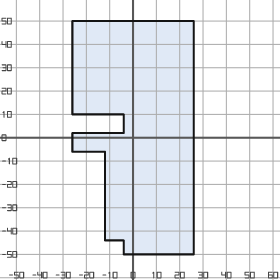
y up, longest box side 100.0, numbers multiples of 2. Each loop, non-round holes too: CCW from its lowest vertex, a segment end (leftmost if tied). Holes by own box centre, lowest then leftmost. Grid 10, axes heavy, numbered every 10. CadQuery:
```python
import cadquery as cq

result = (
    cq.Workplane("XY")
    .moveTo(-4.0, -50.0)
    .lineTo(26.0, -50.0)
    .lineTo(26.0, 50.0)
    .lineTo(-26.0, 50.0)
    .lineTo(-26.0, 10.0)
    .lineTo(-4.0, 10.0)
    .lineTo(-4.0, 2.0)
    .lineTo(-26.0, 2.0)
    .lineTo(-26.0, -6.0)
    .lineTo(-12.0, -6.0)
    .lineTo(-12.0, -44.0)
    .lineTo(-4.0, -44.0)
    .close()
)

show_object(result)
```